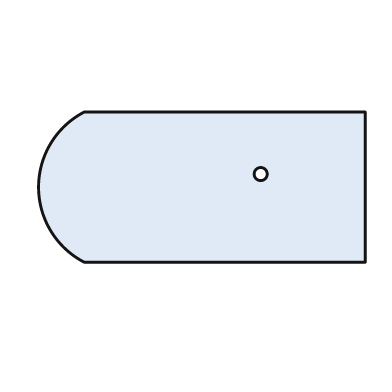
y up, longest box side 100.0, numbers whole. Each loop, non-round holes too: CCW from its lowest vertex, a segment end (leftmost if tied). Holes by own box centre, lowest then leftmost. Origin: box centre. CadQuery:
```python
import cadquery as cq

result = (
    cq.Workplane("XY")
    .moveTo(-36.0, -23.0)
    .lineTo(50.0, -23.0)
    .lineTo(50.0, 23.0)
    .lineTo(-36.0, 23.0)
    .threePointArc((-50.0, 0.0), (-36.0, -23.0))
    .close()
    .moveTo(18.0, 4.0)
    .circle(2.0)
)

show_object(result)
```